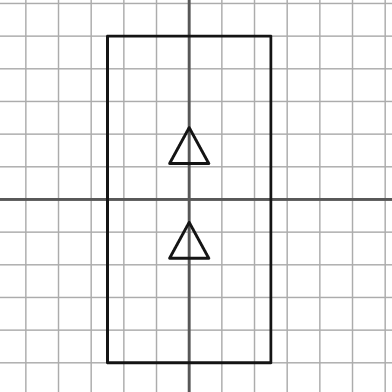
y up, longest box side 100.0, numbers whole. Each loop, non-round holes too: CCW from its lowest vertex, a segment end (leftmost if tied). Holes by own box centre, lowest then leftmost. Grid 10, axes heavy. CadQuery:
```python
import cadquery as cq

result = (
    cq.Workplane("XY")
    .moveTo(-25.0, -50.0)
    .lineTo(25.0, -50.0)
    .lineTo(25.0, 50.0)
    .lineTo(-25.0, 50.0)
    .close()
    .moveTo(-6.0, -18.0)
    .lineTo(6.0, -18.0)
    .lineTo(0.0, -7.0)
    .close()
    .moveTo(-6.0, 11.0)
    .lineTo(6.0, 11.0)
    .lineTo(0.0, 22.0)
    .close()
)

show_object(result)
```